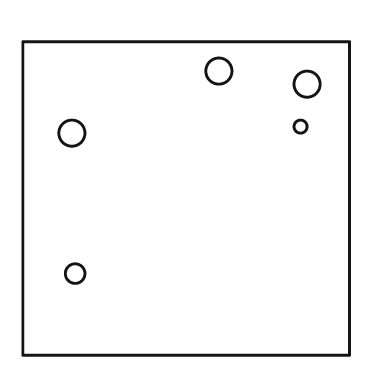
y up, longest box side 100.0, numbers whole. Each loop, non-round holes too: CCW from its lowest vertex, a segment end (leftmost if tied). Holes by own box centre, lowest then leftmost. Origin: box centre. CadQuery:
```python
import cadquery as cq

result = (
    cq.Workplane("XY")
    .moveTo(-50.0, -48.0)
    .lineTo(50.0, -48.0)
    .lineTo(50.0, 48.0)
    .lineTo(-50.0, 48.0)
    .close()
    .moveTo(-34.0, -23.0)
    .circle(3.0)
    .moveTo(-35.0, 20.0)
    .circle(4.0)
    .moveTo(35.0, 22.0)
    .circle(2.0)
    .moveTo(37.0, 35.0)
    .circle(4.0)
    .moveTo(10.0, 39.0)
    .circle(4.0)
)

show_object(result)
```